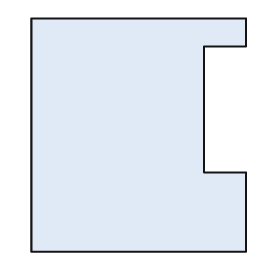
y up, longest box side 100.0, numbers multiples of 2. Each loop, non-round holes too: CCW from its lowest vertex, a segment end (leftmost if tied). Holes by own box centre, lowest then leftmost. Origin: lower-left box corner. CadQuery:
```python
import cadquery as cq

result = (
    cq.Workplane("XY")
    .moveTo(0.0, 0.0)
    .lineTo(92.0, 0.0)
    .lineTo(92.0, 34.0)
    .lineTo(74.0, 34.0)
    .lineTo(74.0, 88.0)
    .lineTo(92.0, 88.0)
    .lineTo(92.0, 100.0)
    .lineTo(0.0, 100.0)
    .close()
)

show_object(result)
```